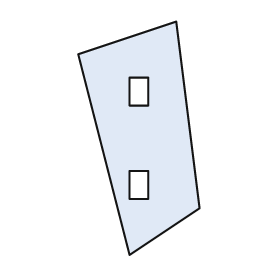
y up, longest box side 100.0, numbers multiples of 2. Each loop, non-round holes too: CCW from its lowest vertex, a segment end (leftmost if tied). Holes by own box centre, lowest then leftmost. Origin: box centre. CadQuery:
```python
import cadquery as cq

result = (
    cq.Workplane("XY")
    .moveTo(-4.0, -50.0)
    .lineTo(26.0, -30.0)
    .lineTo(16.0, 50.0)
    .lineTo(-26.0, 36.0)
    .close()
    .moveTo(-4.0, -26.0)
    .lineTo(4.0, -26.0)
    .lineTo(4.0, -14.0)
    .lineTo(-4.0, -14.0)
    .close()
    .moveTo(-4.0, 14.0)
    .lineTo(4.0, 14.0)
    .lineTo(4.0, 26.0)
    .lineTo(-4.0, 26.0)
    .close()
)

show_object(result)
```